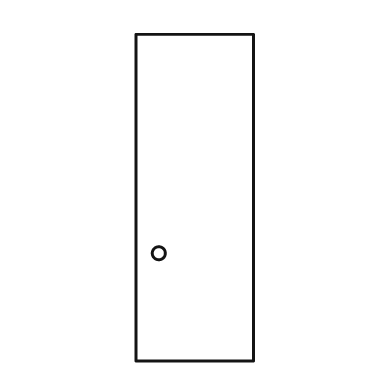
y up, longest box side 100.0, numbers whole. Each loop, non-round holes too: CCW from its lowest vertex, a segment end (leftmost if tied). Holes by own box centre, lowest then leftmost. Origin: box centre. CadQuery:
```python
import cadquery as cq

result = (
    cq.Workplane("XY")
    .moveTo(-18.0, -50.0)
    .lineTo(18.0, -50.0)
    .lineTo(18.0, 50.0)
    .lineTo(-18.0, 50.0)
    .close()
    .moveTo(-11.0, -17.0)
    .circle(2.0)
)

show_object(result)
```